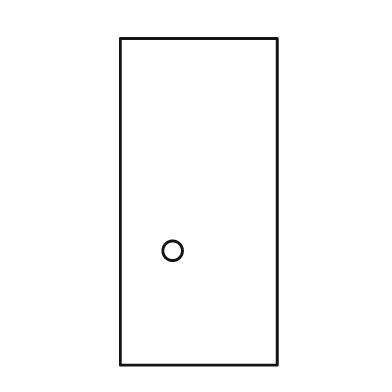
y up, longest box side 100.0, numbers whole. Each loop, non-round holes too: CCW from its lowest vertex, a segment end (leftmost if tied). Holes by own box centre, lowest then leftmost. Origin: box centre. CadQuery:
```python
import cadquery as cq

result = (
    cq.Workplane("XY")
    .moveTo(-24.0, -50.0)
    .lineTo(24.0, -50.0)
    .lineTo(24.0, 50.0)
    .lineTo(-24.0, 50.0)
    .close()
    .moveTo(-8.0, -15.0)
    .circle(3.0)
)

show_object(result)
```